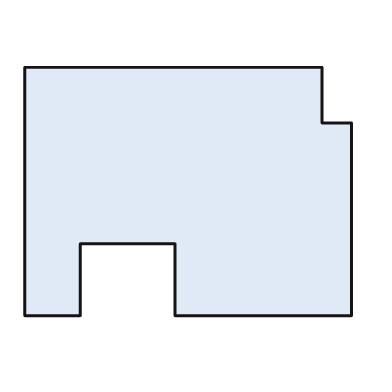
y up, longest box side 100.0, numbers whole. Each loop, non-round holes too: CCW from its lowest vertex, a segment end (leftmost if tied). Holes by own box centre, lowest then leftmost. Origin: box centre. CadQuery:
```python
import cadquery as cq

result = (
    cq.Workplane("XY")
    .moveTo(-50.0, -38.0)
    .lineTo(-33.0, -38.0)
    .lineTo(-33.0, -16.0)
    .lineTo(-4.0, -16.0)
    .lineTo(-4.0, -38.0)
    .lineTo(50.0, -38.0)
    .lineTo(50.0, 21.0)
    .lineTo(41.0, 21.0)
    .lineTo(41.0, 38.0)
    .lineTo(-50.0, 38.0)
    .close()
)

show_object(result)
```